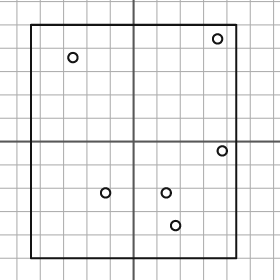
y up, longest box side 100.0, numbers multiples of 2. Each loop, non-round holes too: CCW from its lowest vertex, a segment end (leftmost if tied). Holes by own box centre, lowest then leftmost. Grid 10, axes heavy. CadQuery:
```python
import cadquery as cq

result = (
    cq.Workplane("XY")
    .moveTo(-44.0, -50.0)
    .lineTo(44.0, -50.0)
    .lineTo(44.0, 50.0)
    .lineTo(-44.0, 50.0)
    .close()
    .moveTo(18.0, -36.0)
    .circle(2.0)
    .moveTo(-12.0, -22.0)
    .circle(2.0)
    .moveTo(14.0, -22.0)
    .circle(2.0)
    .moveTo(38.0, -4.0)
    .circle(2.0)
    .moveTo(-26.0, 36.0)
    .circle(2.0)
    .moveTo(36.0, 44.0)
    .circle(2.0)
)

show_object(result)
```